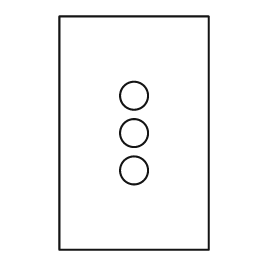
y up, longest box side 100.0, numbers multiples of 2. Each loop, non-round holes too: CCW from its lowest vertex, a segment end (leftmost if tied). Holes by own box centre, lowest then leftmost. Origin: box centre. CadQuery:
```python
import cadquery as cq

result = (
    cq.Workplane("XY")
    .moveTo(-32.0, -50.0)
    .lineTo(32.0, -50.0)
    .lineTo(32.0, 50.0)
    .lineTo(-32.0, 50.0)
    .close()
    .moveTo(0.0, -16.0)
    .circle(6.0)
    .moveTo(0.0, 0.0)
    .circle(6.0)
    .moveTo(0.0, 16.0)
    .circle(6.0)
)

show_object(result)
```